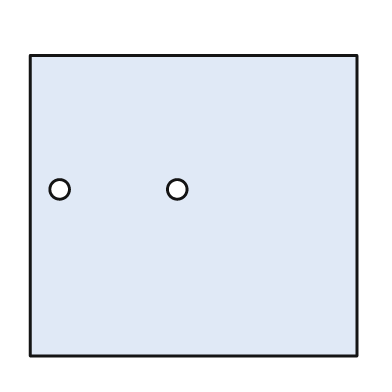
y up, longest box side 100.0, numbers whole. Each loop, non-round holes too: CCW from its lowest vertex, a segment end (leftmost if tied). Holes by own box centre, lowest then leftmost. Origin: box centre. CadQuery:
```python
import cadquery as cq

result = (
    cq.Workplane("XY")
    .moveTo(-50.0, -46.0)
    .lineTo(50.0, -46.0)
    .lineTo(50.0, 46.0)
    .lineTo(-50.0, 46.0)
    .close()
    .moveTo(-41.0, 5.0)
    .circle(3.0)
    .moveTo(-5.0, 5.0)
    .circle(3.0)
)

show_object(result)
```